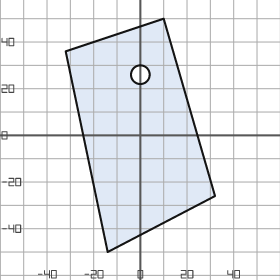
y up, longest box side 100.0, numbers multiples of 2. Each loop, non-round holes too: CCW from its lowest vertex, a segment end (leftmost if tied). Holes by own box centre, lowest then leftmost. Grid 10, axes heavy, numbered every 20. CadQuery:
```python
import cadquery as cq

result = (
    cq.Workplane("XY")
    .moveTo(-14.0, -50.0)
    .lineTo(32.0, -26.0)
    .lineTo(10.0, 50.0)
    .lineTo(-32.0, 36.0)
    .close()
    .moveTo(0.0, 26.0)
    .circle(4.0)
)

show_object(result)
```